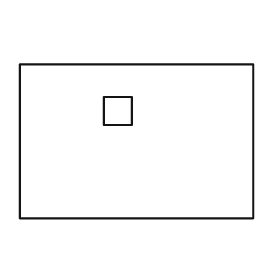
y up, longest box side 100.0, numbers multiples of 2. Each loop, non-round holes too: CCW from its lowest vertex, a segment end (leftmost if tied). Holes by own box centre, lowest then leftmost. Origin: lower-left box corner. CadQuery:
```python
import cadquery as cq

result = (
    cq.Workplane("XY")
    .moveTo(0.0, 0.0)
    .lineTo(100.0, 0.0)
    .lineTo(100.0, 66.0)
    .lineTo(0.0, 66.0)
    .close()
    .moveTo(36.0, 40.0)
    .lineTo(48.0, 40.0)
    .lineTo(48.0, 52.0)
    .lineTo(36.0, 52.0)
    .close()
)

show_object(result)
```